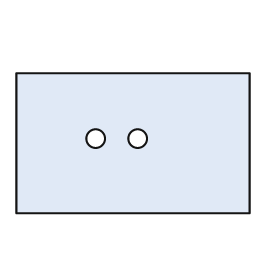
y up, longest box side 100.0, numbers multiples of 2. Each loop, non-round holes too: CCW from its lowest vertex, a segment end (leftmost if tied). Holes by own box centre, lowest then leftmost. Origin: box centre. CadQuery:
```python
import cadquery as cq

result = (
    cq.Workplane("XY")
    .moveTo(-50.0, -30.0)
    .lineTo(50.0, -30.0)
    .lineTo(50.0, 30.0)
    .lineTo(-50.0, 30.0)
    .close()
    .moveTo(-16.0, 2.0)
    .circle(4.0)
    .moveTo(2.0, 2.0)
    .circle(4.0)
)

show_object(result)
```